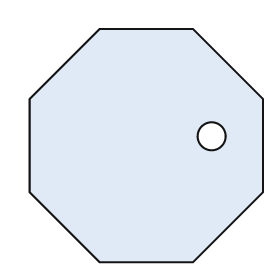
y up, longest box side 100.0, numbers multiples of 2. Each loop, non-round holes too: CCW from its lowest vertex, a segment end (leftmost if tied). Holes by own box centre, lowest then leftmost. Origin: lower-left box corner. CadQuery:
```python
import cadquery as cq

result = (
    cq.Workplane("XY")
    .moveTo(30.0, 0.0)
    .lineTo(70.0, 0.0)
    .lineTo(100.0, 30.0)
    .lineTo(100.0, 70.0)
    .lineTo(70.0, 100.0)
    .lineTo(30.0, 100.0)
    .lineTo(0.0, 70.0)
    .lineTo(0.0, 30.0)
    .close()
    .moveTo(78.0, 54.0)
    .circle(6.0)
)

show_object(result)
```